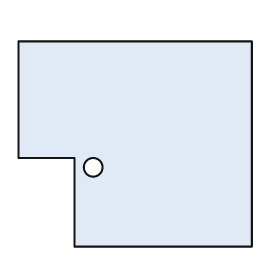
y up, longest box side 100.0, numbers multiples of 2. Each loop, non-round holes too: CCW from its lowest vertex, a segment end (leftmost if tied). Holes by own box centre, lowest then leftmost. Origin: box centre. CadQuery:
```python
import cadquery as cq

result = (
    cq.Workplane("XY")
    .moveTo(-26.0, -44.0)
    .lineTo(50.0, -44.0)
    .lineTo(50.0, 44.0)
    .lineTo(-50.0, 44.0)
    .lineTo(-50.0, -6.0)
    .lineTo(-26.0, -6.0)
    .close()
    .moveTo(-18.0, -10.0)
    .circle(4.0)
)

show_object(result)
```